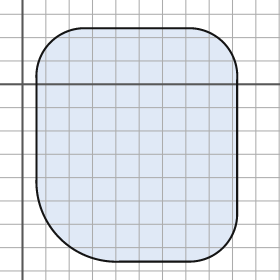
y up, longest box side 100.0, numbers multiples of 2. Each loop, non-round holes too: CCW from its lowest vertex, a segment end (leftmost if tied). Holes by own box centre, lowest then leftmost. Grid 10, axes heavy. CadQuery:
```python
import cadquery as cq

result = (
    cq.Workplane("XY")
    .moveTo(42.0, -76.0)
    .lineTo(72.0, -76.0)
    .threePointArc((86.0, -70.0), (92.0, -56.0))
    .lineTo(92.0, 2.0)
    .threePointArc((86.0, 18.0), (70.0, 24.0))
    .lineTo(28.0, 24.0)
    .threePointArc((12.0, 18.0), (6.0, 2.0))
    .lineTo(6.0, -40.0)
    .threePointArc((16.0, -66.0), (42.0, -76.0))
    .close()
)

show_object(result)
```